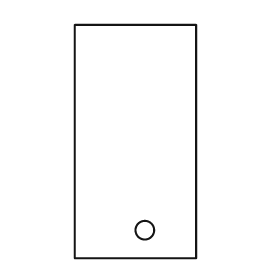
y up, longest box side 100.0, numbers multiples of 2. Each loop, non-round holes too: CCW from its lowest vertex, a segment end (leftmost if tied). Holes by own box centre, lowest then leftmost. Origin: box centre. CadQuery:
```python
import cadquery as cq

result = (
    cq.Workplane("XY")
    .moveTo(-26.0, -50.0)
    .lineTo(26.0, -50.0)
    .lineTo(26.0, 50.0)
    .lineTo(-26.0, 50.0)
    .close()
    .moveTo(4.0, -38.0)
    .circle(4.0)
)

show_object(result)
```